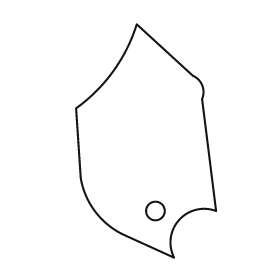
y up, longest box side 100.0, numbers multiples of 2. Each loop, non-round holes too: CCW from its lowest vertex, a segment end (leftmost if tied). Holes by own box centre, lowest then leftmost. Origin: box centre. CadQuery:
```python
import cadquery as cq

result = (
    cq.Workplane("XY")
    .moveTo(12.0, -50.0)
    .threePointArc((14.0, -34.0), (30.0, -30.0))
    .lineTo(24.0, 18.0)
    .threePointArc((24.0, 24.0), (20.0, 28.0))
    .lineTo(-4.0, 50.0)
    .threePointArc((-14.0, 30.0), (-30.0, 14.0))
    .lineTo(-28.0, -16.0)
    .threePointArc((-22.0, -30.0), (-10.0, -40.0))
    .close()
    .moveTo(4.0, -30.0)
    .circle(4.0)
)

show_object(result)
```